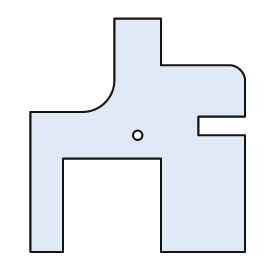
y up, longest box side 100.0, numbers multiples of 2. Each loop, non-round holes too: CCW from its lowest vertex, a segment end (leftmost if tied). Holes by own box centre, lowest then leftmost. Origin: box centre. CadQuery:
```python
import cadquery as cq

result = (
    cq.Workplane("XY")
    .moveTo(-46.0, -50.0)
    .lineTo(-32.0, -50.0)
    .lineTo(-32.0, -10.0)
    .lineTo(10.0, -10.0)
    .lineTo(10.0, -50.0)
    .lineTo(46.0, -50.0)
    .lineTo(46.0, 0.0)
    .lineTo(26.0, 0.0)
    .lineTo(26.0, 8.0)
    .lineTo(46.0, 8.0)
    .lineTo(46.0, 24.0)
    .threePointArc((44.0, 28.0), (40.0, 30.0))
    .lineTo(10.0, 30.0)
    .lineTo(10.0, 50.0)
    .lineTo(-10.0, 50.0)
    .lineTo(-10.0, 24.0)
    .threePointArc((-14.0, 14.0), (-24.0, 10.0))
    .lineTo(-46.0, 10.0)
    .close()
    .moveTo(0.0, 0.0)
    .circle(2.0)
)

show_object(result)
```